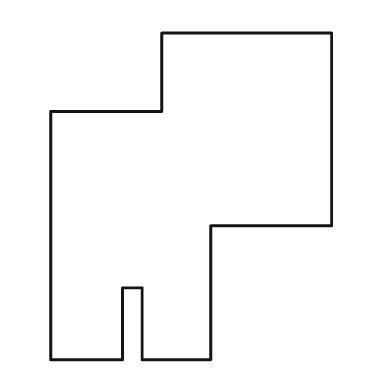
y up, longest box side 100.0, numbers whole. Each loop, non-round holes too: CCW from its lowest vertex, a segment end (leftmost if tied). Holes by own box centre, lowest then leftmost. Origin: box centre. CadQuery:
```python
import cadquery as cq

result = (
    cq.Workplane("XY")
    .moveTo(-43.0, -50.0)
    .lineTo(-21.0, -50.0)
    .lineTo(-21.0, -28.0)
    .lineTo(-15.0, -28.0)
    .lineTo(-15.0, -50.0)
    .lineTo(6.0, -50.0)
    .lineTo(6.0, -9.0)
    .lineTo(43.0, -9.0)
    .lineTo(43.0, 50.0)
    .lineTo(-9.0, 50.0)
    .lineTo(-9.0, 26.0)
    .lineTo(-43.0, 26.0)
    .close()
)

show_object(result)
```